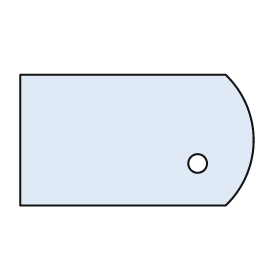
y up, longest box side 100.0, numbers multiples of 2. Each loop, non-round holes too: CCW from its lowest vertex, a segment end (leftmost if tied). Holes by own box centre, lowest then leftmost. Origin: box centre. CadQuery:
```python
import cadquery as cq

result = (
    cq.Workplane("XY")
    .moveTo(-50.0, -28.0)
    .lineTo(38.0, -28.0)
    .threePointArc((50.0, 0.0), (38.0, 28.0))
    .lineTo(-50.0, 28.0)
    .close()
    .moveTo(26.0, -10.0)
    .circle(4.0)
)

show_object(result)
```